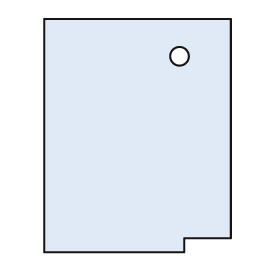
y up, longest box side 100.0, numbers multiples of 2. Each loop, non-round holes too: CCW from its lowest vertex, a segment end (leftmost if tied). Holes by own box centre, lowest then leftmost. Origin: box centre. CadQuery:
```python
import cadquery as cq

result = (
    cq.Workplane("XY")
    .moveTo(-40.0, -50.0)
    .lineTo(20.0, -50.0)
    .lineTo(20.0, -44.0)
    .lineTo(40.0, -44.0)
    .lineTo(40.0, 50.0)
    .lineTo(-40.0, 50.0)
    .close()
    .moveTo(18.0, 34.0)
    .circle(4.0)
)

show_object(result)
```